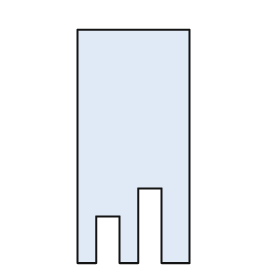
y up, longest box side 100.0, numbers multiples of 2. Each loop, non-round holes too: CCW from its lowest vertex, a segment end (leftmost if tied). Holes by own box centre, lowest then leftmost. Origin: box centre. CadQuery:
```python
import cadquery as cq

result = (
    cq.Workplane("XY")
    .moveTo(-24.0, -50.0)
    .lineTo(-16.0, -50.0)
    .lineTo(-16.0, -30.0)
    .lineTo(-6.0, -30.0)
    .lineTo(-6.0, -50.0)
    .lineTo(2.0, -50.0)
    .lineTo(2.0, -18.0)
    .lineTo(12.0, -18.0)
    .lineTo(12.0, -50.0)
    .lineTo(24.0, -50.0)
    .lineTo(24.0, 50.0)
    .lineTo(-24.0, 50.0)
    .close()
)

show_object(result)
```